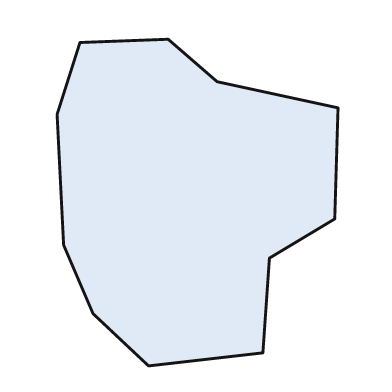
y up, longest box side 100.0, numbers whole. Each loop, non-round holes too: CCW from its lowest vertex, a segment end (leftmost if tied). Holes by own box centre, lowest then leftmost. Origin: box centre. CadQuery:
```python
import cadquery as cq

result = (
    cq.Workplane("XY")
    .moveTo(-15.0, -50.0)
    .lineTo(20.0, -46.0)
    .lineTo(22.0, -17.0)
    .lineTo(42.0, -5.0)
    .lineTo(43.0, 29.0)
    .lineTo(6.0, 37.0)
    .lineTo(-9.0, 50.0)
    .lineTo(-36.0, 49.0)
    .lineTo(-43.0, 27.0)
    .lineTo(-41.0, -13.0)
    .lineTo(-32.0, -34.0)
    .close()
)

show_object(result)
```